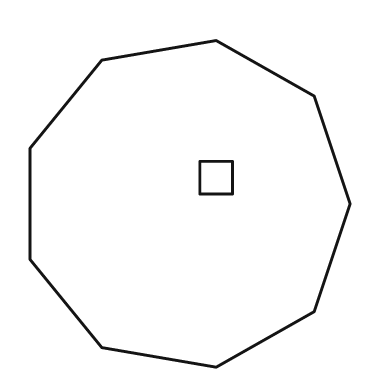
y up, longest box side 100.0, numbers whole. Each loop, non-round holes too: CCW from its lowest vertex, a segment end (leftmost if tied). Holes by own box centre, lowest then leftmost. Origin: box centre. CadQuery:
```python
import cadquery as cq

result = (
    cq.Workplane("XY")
    .moveTo(8.0, -50.0)
    .lineTo(38.0, -33.0)
    .lineTo(49.0, 0.0)
    .lineTo(38.0, 33.0)
    .lineTo(8.0, 50.0)
    .lineTo(-27.0, 44.0)
    .lineTo(-49.0, 17.0)
    .lineTo(-49.0, -17.0)
    .lineTo(-27.0, -44.0)
    .close()
    .moveTo(3.0, 3.0)
    .lineTo(13.0, 3.0)
    .lineTo(13.0, 13.0)
    .lineTo(3.0, 13.0)
    .close()
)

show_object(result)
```